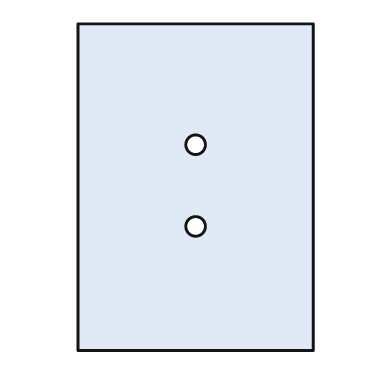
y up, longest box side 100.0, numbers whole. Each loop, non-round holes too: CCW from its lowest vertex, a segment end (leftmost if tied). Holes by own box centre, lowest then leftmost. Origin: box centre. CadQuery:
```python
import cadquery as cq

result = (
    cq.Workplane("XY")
    .moveTo(-36.0, -50.0)
    .lineTo(36.0, -50.0)
    .lineTo(36.0, 50.0)
    .lineTo(-36.0, 50.0)
    .close()
    .moveTo(0.0, -12.0)
    .circle(3.0)
    .moveTo(0.0, 13.0)
    .circle(3.0)
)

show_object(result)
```